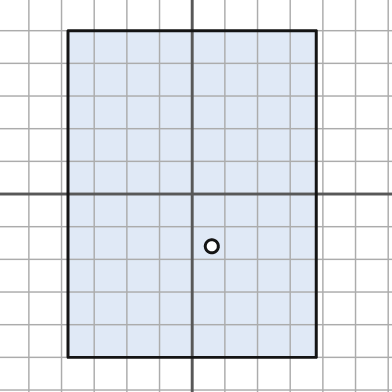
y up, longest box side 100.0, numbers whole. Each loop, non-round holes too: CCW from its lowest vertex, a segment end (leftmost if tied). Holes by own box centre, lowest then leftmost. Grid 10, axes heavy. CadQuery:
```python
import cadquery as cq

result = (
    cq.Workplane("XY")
    .moveTo(-38.0, -50.0)
    .lineTo(38.0, -50.0)
    .lineTo(38.0, 50.0)
    .lineTo(-38.0, 50.0)
    .close()
    .moveTo(6.0, -16.0)
    .circle(2.0)
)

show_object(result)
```